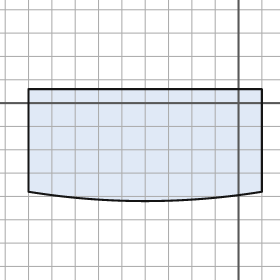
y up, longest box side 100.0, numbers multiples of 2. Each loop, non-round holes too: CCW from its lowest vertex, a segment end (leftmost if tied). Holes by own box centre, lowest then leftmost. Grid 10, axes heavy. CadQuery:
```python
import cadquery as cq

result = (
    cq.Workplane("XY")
    .moveTo(-90.0, -38.0)
    .threePointArc((-40.0, -42.0), (10.0, -38.0))
    .lineTo(10.0, 6.0)
    .lineTo(-90.0, 6.0)
    .close()
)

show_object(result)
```